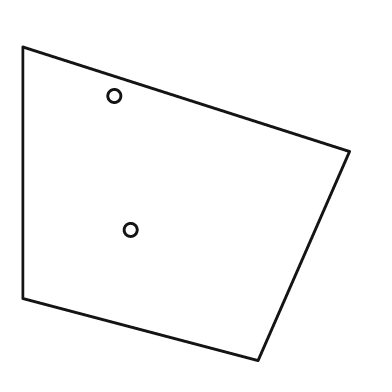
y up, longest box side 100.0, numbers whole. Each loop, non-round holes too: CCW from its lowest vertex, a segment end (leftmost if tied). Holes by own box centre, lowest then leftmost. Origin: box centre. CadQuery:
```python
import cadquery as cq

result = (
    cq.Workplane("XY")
    .moveTo(22.0, -48.0)
    .lineTo(50.0, 16.0)
    .lineTo(-50.0, 48.0)
    .lineTo(-50.0, -29.0)
    .close()
    .moveTo(-17.0, -8.0)
    .circle(2.0)
    .moveTo(-22.0, 33.0)
    .circle(2.0)
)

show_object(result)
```